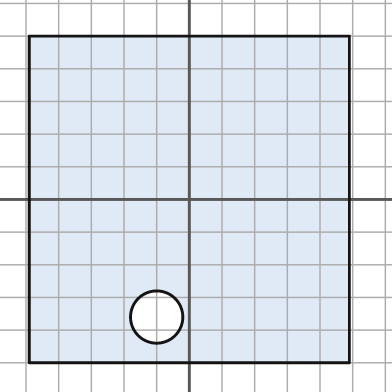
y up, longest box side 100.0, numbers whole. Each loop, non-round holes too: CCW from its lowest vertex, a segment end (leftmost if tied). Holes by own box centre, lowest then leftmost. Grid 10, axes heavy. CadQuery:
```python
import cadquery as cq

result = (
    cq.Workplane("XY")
    .moveTo(-49.0, -50.0)
    .lineTo(49.0, -50.0)
    .lineTo(49.0, 50.0)
    .lineTo(-49.0, 50.0)
    .close()
    .moveTo(-10.0, -36.0)
    .circle(8.0)
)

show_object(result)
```